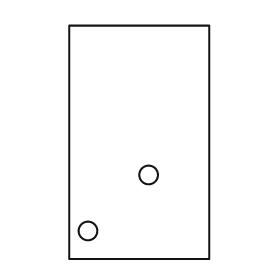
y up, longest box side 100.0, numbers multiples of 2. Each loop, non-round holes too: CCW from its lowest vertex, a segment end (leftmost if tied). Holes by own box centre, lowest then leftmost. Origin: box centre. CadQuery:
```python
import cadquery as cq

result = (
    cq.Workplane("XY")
    .moveTo(-30.0, -50.0)
    .lineTo(30.0, -50.0)
    .lineTo(30.0, 50.0)
    .lineTo(-30.0, 50.0)
    .close()
    .moveTo(-22.0, -38.0)
    .circle(4.0)
    .moveTo(4.0, -14.0)
    .circle(4.0)
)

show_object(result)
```